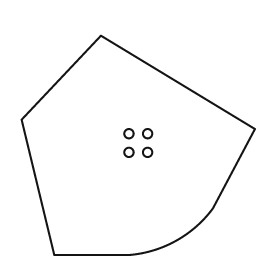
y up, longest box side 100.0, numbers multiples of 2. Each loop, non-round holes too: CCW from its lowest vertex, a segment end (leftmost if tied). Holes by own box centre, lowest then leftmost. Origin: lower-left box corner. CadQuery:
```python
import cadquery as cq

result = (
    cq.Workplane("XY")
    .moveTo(14.0, 0.0)
    .lineTo(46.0, 0.0)
    .threePointArc((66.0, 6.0), (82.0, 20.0))
    .lineTo(100.0, 54.0)
    .lineTo(34.0, 94.0)
    .lineTo(0.0, 58.0)
    .close()
    .moveTo(46.0, 44.0)
    .circle(2.0)
    .moveTo(54.0, 44.0)
    .circle(2.0)
    .moveTo(46.0, 52.0)
    .circle(2.0)
    .moveTo(54.0, 52.0)
    .circle(2.0)
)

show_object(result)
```